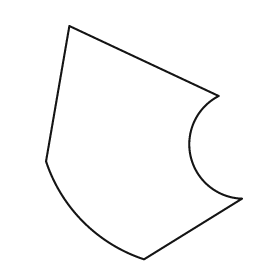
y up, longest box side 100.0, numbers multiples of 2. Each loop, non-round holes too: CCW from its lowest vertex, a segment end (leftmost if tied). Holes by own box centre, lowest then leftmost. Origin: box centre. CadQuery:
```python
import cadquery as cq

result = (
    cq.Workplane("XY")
    .moveTo(0.0, -50.0)
    .lineTo(42.0, -24.0)
    .threePointArc((20.0, -6.0), (32.0, 20.0))
    .lineTo(-32.0, 50.0)
    .lineTo(-42.0, -8.0)
    .threePointArc((-26.0, -34.0), (0.0, -50.0))
    .close()
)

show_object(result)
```